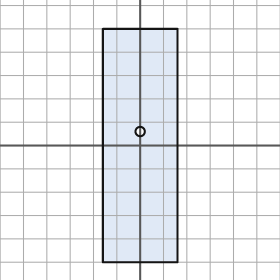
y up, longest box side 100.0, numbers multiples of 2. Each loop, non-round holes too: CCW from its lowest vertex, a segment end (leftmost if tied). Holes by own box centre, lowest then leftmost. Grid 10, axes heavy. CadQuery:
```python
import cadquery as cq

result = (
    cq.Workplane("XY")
    .moveTo(-16.0, -50.0)
    .lineTo(16.0, -50.0)
    .lineTo(16.0, 50.0)
    .lineTo(-16.0, 50.0)
    .close()
    .moveTo(0.0, 6.0)
    .circle(2.0)
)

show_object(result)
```